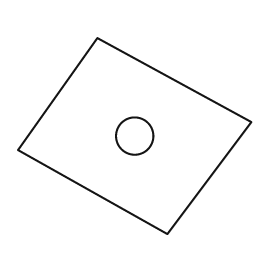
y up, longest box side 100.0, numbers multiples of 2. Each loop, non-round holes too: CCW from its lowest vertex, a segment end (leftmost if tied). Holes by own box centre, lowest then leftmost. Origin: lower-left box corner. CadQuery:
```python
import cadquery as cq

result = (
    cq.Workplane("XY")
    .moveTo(64.0, 0.0)
    .lineTo(100.0, 48.0)
    .lineTo(34.0, 84.0)
    .lineTo(0.0, 36.0)
    .close()
    .moveTo(50.0, 42.0)
    .circle(8.0)
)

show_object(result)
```